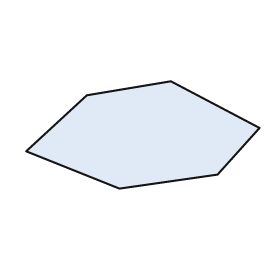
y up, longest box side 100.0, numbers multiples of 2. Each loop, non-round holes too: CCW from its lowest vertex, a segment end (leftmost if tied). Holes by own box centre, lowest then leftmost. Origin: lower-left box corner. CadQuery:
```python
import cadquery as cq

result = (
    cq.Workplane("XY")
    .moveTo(40.0, 0.0)
    .lineTo(82.0, 6.0)
    .lineTo(100.0, 26.0)
    .lineTo(62.0, 46.0)
    .lineTo(26.0, 40.0)
    .lineTo(0.0, 16.0)
    .close()
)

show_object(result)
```